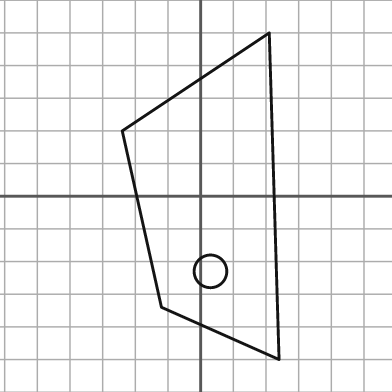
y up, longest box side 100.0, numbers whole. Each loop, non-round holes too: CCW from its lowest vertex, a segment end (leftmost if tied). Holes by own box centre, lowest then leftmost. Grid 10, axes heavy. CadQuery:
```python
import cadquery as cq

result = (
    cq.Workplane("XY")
    .moveTo(24.0, -50.0)
    .lineTo(21.0, 50.0)
    .lineTo(-24.0, 20.0)
    .lineTo(-12.0, -34.0)
    .close()
    .moveTo(3.0, -23.0)
    .circle(5.0)
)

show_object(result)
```